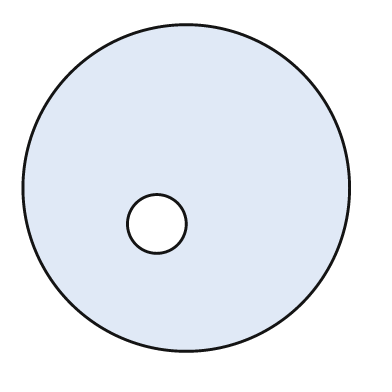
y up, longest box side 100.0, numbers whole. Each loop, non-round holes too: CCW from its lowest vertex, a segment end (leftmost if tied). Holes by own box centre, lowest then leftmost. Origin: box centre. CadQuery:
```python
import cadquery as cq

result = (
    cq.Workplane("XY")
    .moveTo(0.0, 0.0)
    .circle(50.0)
    .moveTo(-9.0, -11.0)
    .circle(9.0)
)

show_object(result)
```